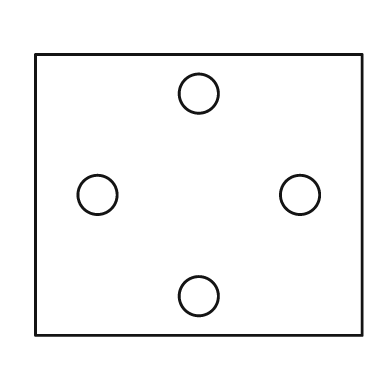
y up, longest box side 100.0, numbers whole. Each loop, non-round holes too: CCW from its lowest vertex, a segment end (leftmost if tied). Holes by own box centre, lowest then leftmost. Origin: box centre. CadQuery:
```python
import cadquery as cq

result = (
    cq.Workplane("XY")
    .moveTo(-50.0, -43.0)
    .lineTo(50.0, -43.0)
    .lineTo(50.0, 43.0)
    .lineTo(-50.0, 43.0)
    .close()
    .moveTo(0.0, -31.0)
    .circle(6.0)
    .moveTo(-31.0, 0.0)
    .circle(6.0)
    .moveTo(31.0, 0.0)
    .circle(6.0)
    .moveTo(0.0, 31.0)
    .circle(6.0)
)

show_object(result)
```